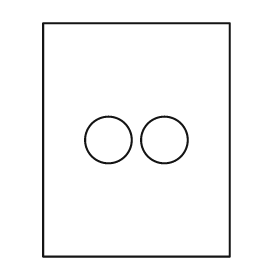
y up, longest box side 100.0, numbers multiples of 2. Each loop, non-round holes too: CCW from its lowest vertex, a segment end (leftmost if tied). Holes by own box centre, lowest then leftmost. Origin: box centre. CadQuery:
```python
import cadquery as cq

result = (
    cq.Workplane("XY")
    .moveTo(-40.0, -50.0)
    .lineTo(40.0, -50.0)
    .lineTo(40.0, 50.0)
    .lineTo(-40.0, 50.0)
    .close()
    .moveTo(-12.0, 0.0)
    .circle(10.0)
    .moveTo(12.0, 0.0)
    .circle(10.0)
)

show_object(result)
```